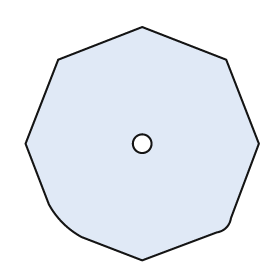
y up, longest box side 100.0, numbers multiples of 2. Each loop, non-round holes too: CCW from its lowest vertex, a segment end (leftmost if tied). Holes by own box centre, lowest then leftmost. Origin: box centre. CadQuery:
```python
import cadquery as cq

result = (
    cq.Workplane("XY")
    .moveTo(0.0, -50.0)
    .lineTo(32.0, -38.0)
    .threePointArc((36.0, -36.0), (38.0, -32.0))
    .lineTo(50.0, 0.0)
    .lineTo(36.0, 36.0)
    .lineTo(0.0, 50.0)
    .lineTo(-36.0, 36.0)
    .lineTo(-50.0, 0.0)
    .lineTo(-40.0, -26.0)
    .threePointArc((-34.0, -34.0), (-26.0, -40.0))
    .close()
    .moveTo(0.0, 0.0)
    .circle(4.0)
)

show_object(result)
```